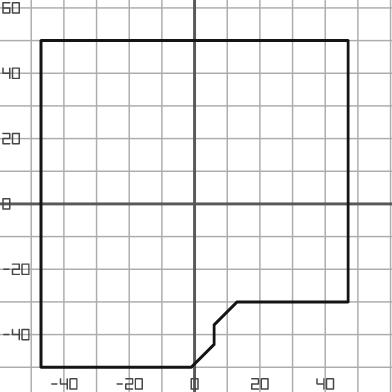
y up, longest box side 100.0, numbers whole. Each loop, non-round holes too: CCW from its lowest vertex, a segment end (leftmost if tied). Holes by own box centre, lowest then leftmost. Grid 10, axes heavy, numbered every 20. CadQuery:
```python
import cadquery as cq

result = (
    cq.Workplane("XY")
    .moveTo(-47.0, -50.0)
    .lineTo(-1.0, -50.0)
    .lineTo(6.0, -43.0)
    .lineTo(6.0, -37.0)
    .lineTo(13.0, -30.0)
    .lineTo(47.0, -30.0)
    .lineTo(47.0, 50.0)
    .lineTo(-47.0, 50.0)
    .close()
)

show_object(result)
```